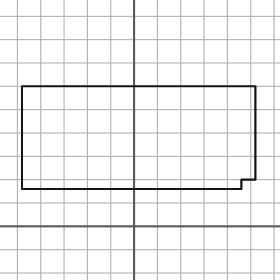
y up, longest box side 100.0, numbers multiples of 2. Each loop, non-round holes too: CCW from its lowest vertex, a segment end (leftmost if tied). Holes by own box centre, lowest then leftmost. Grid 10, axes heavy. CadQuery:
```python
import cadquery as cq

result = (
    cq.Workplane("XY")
    .moveTo(-48.0, 16.0)
    .lineTo(46.0, 16.0)
    .lineTo(46.0, 20.0)
    .lineTo(52.0, 20.0)
    .lineTo(52.0, 60.0)
    .lineTo(-48.0, 60.0)
    .close()
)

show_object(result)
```